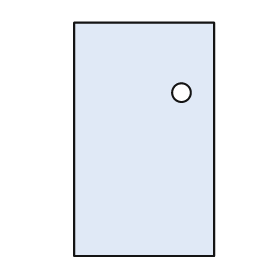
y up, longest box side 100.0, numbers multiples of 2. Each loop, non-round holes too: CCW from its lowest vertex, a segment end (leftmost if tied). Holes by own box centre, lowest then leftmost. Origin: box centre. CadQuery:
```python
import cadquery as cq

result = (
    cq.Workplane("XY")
    .moveTo(-30.0, -50.0)
    .lineTo(30.0, -50.0)
    .lineTo(30.0, 50.0)
    .lineTo(-30.0, 50.0)
    .close()
    .moveTo(16.0, 20.0)
    .circle(4.0)
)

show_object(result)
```